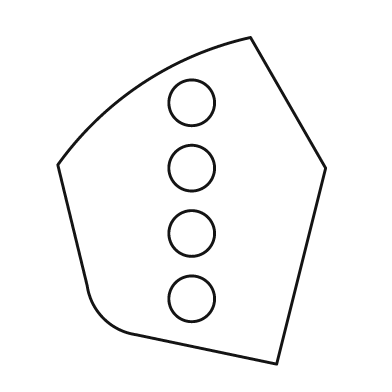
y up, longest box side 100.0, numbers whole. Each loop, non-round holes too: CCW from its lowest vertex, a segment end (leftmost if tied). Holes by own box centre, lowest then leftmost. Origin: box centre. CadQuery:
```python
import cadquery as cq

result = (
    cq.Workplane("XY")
    .moveTo(26.0, -50.0)
    .lineTo(41.0, 10.0)
    .lineTo(18.0, 50.0)
    .threePointArc((-15.0, 36.0), (-41.0, 11.0))
    .lineTo(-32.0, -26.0)
    .threePointArc((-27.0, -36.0), (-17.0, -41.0))
    .close()
    .moveTo(0.0, -30.0)
    .circle(7.0)
    .moveTo(0.0, -10.0)
    .circle(7.0)
    .moveTo(0.0, 10.0)
    .circle(7.0)
    .moveTo(0.0, 30.0)
    .circle(7.0)
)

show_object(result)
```